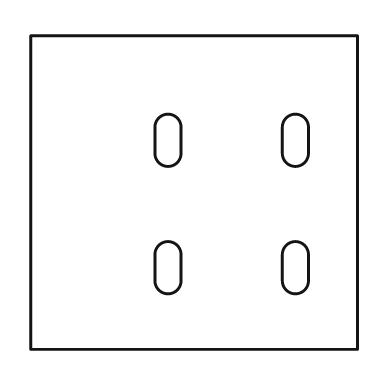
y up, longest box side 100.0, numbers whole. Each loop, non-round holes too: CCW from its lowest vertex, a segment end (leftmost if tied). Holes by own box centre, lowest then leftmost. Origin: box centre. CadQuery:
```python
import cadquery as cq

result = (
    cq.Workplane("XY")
    .moveTo(-50.0, -48.0)
    .lineTo(50.0, -48.0)
    .lineTo(50.0, 48.0)
    .lineTo(-50.0, 48.0)
    .close()
    .moveTo(-12.0, -27.0)
    .threePointArc((-8.0, -31.0), (-4.0, -27.0))
    .lineTo(-4.0, -19.0)
    .threePointArc((-8.0, -15.0), (-12.0, -19.0))
    .close()
    .moveTo(27.0, -27.0)
    .threePointArc((31.0, -31.0), (35.0, -27.0))
    .lineTo(35.0, -19.0)
    .threePointArc((31.0, -15.0), (27.0, -19.0))
    .close()
    .moveTo(-12.0, 12.0)
    .threePointArc((-8.0, 8.0), (-4.0, 12.0))
    .lineTo(-4.0, 20.0)
    .threePointArc((-8.0, 24.0), (-12.0, 20.0))
    .close()
    .moveTo(27.0, 12.0)
    .threePointArc((31.0, 8.0), (35.0, 12.0))
    .lineTo(35.0, 20.0)
    .threePointArc((31.0, 24.0), (27.0, 20.0))
    .close()
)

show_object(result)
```